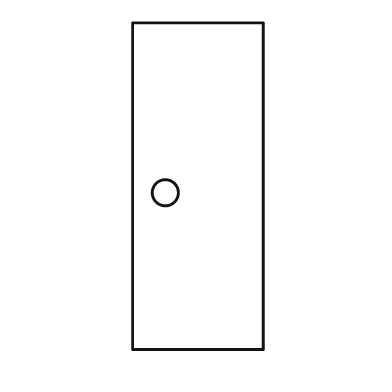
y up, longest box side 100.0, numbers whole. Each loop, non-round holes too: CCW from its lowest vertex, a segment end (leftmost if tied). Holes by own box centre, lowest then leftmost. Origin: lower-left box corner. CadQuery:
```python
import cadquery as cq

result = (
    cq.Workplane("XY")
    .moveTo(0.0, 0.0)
    .lineTo(40.0, 0.0)
    .lineTo(40.0, 100.0)
    .lineTo(0.0, 100.0)
    .close()
    .moveTo(10.0, 48.0)
    .circle(4.0)
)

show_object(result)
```